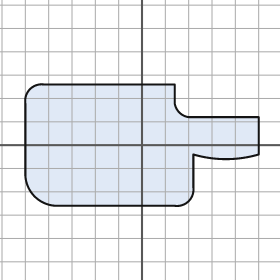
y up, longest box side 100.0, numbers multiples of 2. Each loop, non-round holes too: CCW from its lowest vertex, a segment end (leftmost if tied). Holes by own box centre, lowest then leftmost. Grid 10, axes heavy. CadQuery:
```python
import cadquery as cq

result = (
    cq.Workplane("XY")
    .moveTo(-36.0, -26.0)
    .lineTo(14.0, -26.0)
    .threePointArc((20.0, -24.0), (22.0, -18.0))
    .lineTo(22.0, -4.0)
    .threePointArc((36.0, -6.0), (50.0, -4.0))
    .lineTo(50.0, 12.0)
    .lineTo(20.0, 12.0)
    .threePointArc((16.0, 14.0), (14.0, 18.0))
    .lineTo(14.0, 26.0)
    .lineTo(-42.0, 26.0)
    .threePointArc((-48.0, 24.0), (-50.0, 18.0))
    .lineTo(-50.0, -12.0)
    .threePointArc((-46.0, -22.0), (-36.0, -26.0))
    .close()
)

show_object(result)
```